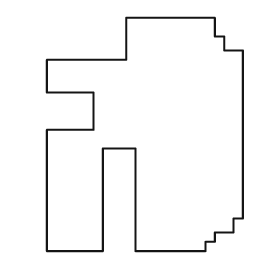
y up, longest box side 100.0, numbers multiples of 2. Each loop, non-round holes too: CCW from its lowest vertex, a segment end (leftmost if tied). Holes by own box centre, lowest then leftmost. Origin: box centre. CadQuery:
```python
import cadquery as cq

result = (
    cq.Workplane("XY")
    .moveTo(-42.0, -50.0)
    .lineTo(-18.0, -50.0)
    .lineTo(-18.0, -6.0)
    .lineTo(-4.0, -6.0)
    .lineTo(-4.0, -50.0)
    .lineTo(26.0, -50.0)
    .lineTo(26.0, -46.0)
    .lineTo(30.0, -46.0)
    .lineTo(30.0, -42.0)
    .lineTo(38.0, -42.0)
    .lineTo(38.0, -36.0)
    .lineTo(42.0, -36.0)
    .lineTo(42.0, 36.0)
    .lineTo(34.0, 36.0)
    .lineTo(34.0, 42.0)
    .lineTo(30.0, 42.0)
    .lineTo(30.0, 50.0)
    .lineTo(-8.0, 50.0)
    .lineTo(-8.0, 32.0)
    .lineTo(-42.0, 32.0)
    .lineTo(-42.0, 18.0)
    .lineTo(-22.0, 18.0)
    .lineTo(-22.0, 2.0)
    .lineTo(-42.0, 2.0)
    .close()
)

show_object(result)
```